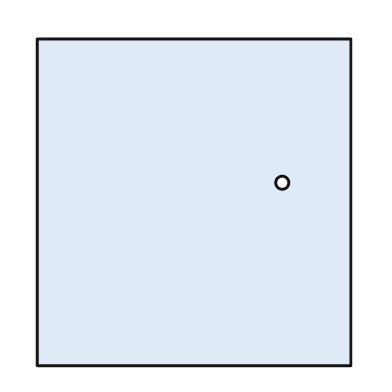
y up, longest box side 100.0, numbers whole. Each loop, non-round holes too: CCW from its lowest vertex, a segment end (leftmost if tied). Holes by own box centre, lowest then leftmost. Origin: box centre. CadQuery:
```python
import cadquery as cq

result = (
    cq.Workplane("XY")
    .moveTo(-48.0, -50.0)
    .lineTo(48.0, -50.0)
    .lineTo(48.0, 50.0)
    .lineTo(-48.0, 50.0)
    .close()
    .moveTo(27.0, 6.0)
    .circle(2.0)
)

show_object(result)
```